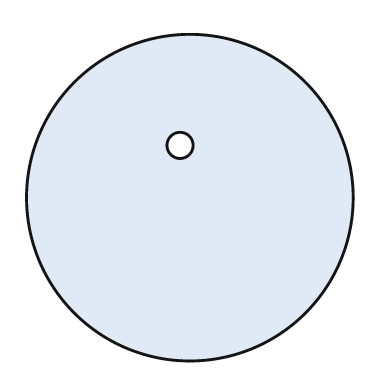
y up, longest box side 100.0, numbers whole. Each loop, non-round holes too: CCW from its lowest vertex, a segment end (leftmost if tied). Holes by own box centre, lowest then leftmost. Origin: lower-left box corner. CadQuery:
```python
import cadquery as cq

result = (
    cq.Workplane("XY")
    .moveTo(50.0, 50.0)
    .circle(50.0)
    .moveTo(47.0, 66.0)
    .circle(4.0)
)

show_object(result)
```